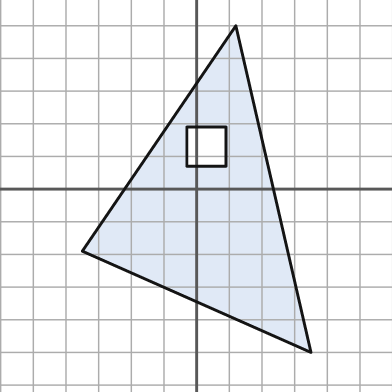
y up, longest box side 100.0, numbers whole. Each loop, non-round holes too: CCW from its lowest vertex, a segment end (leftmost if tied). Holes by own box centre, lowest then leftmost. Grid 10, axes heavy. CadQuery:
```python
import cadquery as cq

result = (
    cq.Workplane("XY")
    .moveTo(35.0, -50.0)
    .lineTo(12.0, 50.0)
    .lineTo(-35.0, -19.0)
    .close()
    .moveTo(-3.0, 7.0)
    .lineTo(9.0, 7.0)
    .lineTo(9.0, 19.0)
    .lineTo(-3.0, 19.0)
    .close()
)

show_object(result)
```